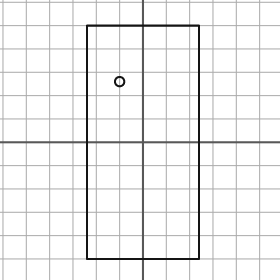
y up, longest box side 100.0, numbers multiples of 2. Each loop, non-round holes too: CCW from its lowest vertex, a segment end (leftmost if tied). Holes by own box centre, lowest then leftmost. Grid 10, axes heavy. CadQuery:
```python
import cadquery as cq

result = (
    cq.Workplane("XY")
    .moveTo(-24.0, -50.0)
    .lineTo(24.0, -50.0)
    .lineTo(24.0, 50.0)
    .lineTo(-24.0, 50.0)
    .close()
    .moveTo(-10.0, 26.0)
    .circle(2.0)
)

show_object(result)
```